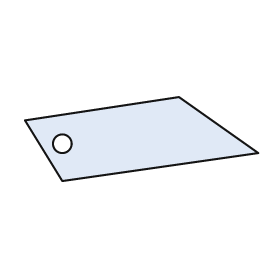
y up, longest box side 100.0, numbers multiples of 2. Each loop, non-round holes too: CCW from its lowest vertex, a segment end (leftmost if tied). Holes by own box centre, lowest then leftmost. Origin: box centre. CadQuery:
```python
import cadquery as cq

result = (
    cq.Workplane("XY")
    .moveTo(-34.0, -18.0)
    .lineTo(50.0, -6.0)
    .lineTo(16.0, 18.0)
    .lineTo(-50.0, 8.0)
    .close()
    .moveTo(-34.0, -2.0)
    .circle(4.0)
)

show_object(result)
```